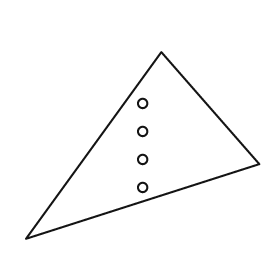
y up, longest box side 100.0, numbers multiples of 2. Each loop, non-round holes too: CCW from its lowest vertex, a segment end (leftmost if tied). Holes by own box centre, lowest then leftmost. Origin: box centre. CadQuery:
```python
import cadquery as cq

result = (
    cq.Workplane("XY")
    .moveTo(-50.0, -40.0)
    .lineTo(50.0, -8.0)
    .lineTo(8.0, 40.0)
    .close()
    .moveTo(0.0, -18.0)
    .circle(2.0)
    .moveTo(0.0, -6.0)
    .circle(2.0)
    .moveTo(0.0, 6.0)
    .circle(2.0)
    .moveTo(0.0, 18.0)
    .circle(2.0)
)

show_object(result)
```